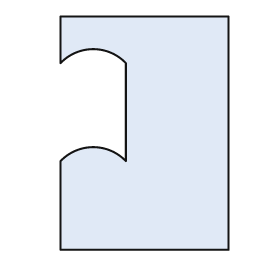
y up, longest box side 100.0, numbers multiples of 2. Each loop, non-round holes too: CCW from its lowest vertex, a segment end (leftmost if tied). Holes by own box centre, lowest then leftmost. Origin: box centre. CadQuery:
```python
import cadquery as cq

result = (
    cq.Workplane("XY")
    .moveTo(-36.0, -50.0)
    .lineTo(36.0, -50.0)
    .lineTo(36.0, 50.0)
    .lineTo(-36.0, 50.0)
    .lineTo(-36.0, 30.0)
    .threePointArc((-22.0, 36.0), (-8.0, 30.0))
    .lineTo(-8.0, -12.0)
    .threePointArc((-22.0, -6.0), (-36.0, -12.0))
    .close()
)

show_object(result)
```